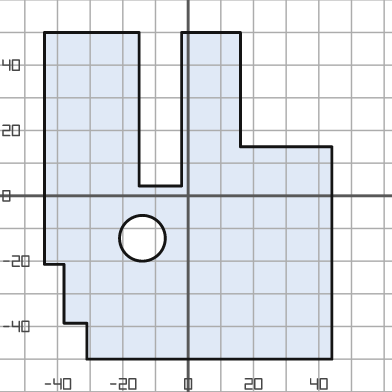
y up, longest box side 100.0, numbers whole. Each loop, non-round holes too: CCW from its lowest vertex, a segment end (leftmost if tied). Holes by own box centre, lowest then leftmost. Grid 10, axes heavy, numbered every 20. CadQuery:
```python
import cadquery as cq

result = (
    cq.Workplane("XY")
    .moveTo(-31.0, -50.0)
    .lineTo(44.0, -50.0)
    .lineTo(44.0, 15.0)
    .lineTo(16.0, 15.0)
    .lineTo(16.0, 50.0)
    .lineTo(-2.0, 50.0)
    .lineTo(-2.0, 3.0)
    .lineTo(-15.0, 3.0)
    .lineTo(-15.0, 50.0)
    .lineTo(-44.0, 50.0)
    .lineTo(-44.0, -21.0)
    .lineTo(-38.0, -21.0)
    .lineTo(-38.0, -39.0)
    .lineTo(-31.0, -39.0)
    .close()
    .moveTo(-14.0, -13.0)
    .circle(7.0)
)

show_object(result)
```